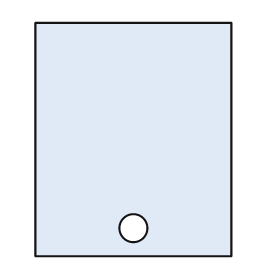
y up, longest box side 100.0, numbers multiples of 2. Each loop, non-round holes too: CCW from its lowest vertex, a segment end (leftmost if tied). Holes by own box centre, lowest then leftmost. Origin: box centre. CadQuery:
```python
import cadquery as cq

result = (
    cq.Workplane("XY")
    .moveTo(-42.0, -50.0)
    .lineTo(42.0, -50.0)
    .lineTo(42.0, 50.0)
    .lineTo(-42.0, 50.0)
    .close()
    .moveTo(0.0, -38.0)
    .circle(6.0)
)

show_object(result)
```